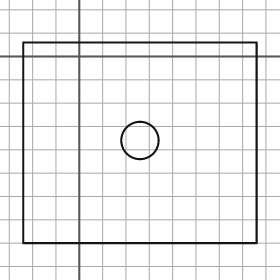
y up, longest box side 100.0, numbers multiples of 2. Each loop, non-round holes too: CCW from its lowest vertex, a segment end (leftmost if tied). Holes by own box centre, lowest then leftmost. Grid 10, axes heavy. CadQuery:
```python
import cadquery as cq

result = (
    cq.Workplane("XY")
    .moveTo(-24.0, -80.0)
    .lineTo(76.0, -80.0)
    .lineTo(76.0, 6.0)
    .lineTo(-24.0, 6.0)
    .close()
    .moveTo(26.0, -36.0)
    .circle(8.0)
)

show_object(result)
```